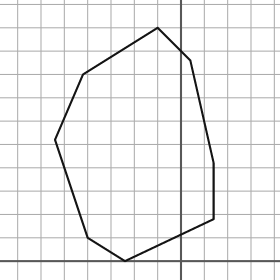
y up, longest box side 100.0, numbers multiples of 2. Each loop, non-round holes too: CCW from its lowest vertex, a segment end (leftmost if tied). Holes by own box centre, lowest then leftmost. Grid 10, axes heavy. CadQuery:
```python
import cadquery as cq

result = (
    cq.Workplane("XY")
    .moveTo(-24.0, 0.0)
    .lineTo(14.0, 18.0)
    .lineTo(14.0, 42.0)
    .lineTo(4.0, 86.0)
    .lineTo(-10.0, 100.0)
    .lineTo(-42.0, 80.0)
    .lineTo(-54.0, 52.0)
    .lineTo(-40.0, 10.0)
    .close()
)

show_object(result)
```